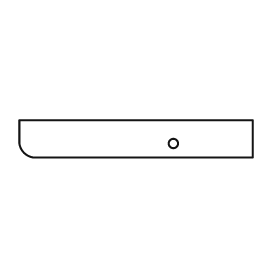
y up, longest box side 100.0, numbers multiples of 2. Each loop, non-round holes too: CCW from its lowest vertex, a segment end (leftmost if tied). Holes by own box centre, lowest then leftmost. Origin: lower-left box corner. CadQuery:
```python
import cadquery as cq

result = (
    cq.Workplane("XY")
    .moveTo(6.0, 0.0)
    .lineTo(100.0, 0.0)
    .lineTo(100.0, 16.0)
    .lineTo(0.0, 16.0)
    .lineTo(0.0, 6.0)
    .threePointArc((2.0, 2.0), (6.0, 0.0))
    .close()
    .moveTo(66.0, 6.0)
    .circle(2.0)
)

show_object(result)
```